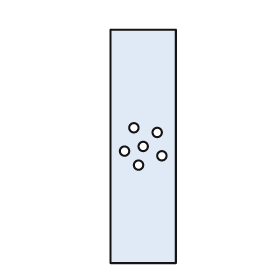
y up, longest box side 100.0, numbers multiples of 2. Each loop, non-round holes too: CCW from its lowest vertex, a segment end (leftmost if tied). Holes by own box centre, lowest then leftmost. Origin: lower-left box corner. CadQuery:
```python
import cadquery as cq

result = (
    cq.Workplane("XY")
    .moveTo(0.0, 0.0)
    .lineTo(28.0, 0.0)
    .lineTo(28.0, 100.0)
    .lineTo(0.0, 100.0)
    .close()
    .moveTo(12.0, 42.0)
    .circle(2.0)
    .moveTo(22.0, 46.0)
    .circle(2.0)
    .moveTo(6.0, 48.0)
    .circle(2.0)
    .moveTo(14.0, 50.0)
    .circle(2.0)
    .moveTo(20.0, 56.0)
    .circle(2.0)
    .moveTo(10.0, 58.0)
    .circle(2.0)
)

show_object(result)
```